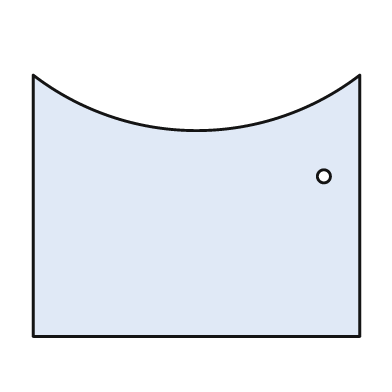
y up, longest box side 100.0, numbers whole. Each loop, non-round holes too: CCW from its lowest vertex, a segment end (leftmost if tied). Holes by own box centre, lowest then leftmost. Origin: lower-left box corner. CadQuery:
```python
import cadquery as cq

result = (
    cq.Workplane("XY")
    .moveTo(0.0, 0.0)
    .lineTo(100.0, 0.0)
    .lineTo(100.0, 80.0)
    .threePointArc((50.0, 63.0), (0.0, 80.0))
    .close()
    .moveTo(89.0, 49.0)
    .circle(2.0)
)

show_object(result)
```